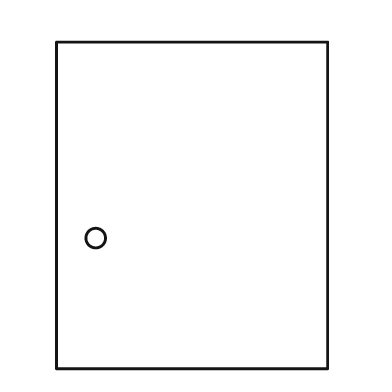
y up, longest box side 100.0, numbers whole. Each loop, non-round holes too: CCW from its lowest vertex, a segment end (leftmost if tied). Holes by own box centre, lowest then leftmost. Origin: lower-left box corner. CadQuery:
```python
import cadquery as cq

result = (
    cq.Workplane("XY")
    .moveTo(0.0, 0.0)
    .lineTo(83.0, 0.0)
    .lineTo(83.0, 100.0)
    .lineTo(0.0, 100.0)
    .close()
    .moveTo(12.0, 40.0)
    .circle(3.0)
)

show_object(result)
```